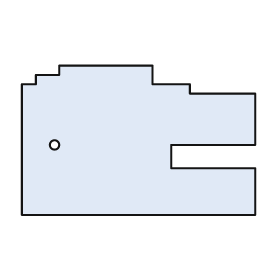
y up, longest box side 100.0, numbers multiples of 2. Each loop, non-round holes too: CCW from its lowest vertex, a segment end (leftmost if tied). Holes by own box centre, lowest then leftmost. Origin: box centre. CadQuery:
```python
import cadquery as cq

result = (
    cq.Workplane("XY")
    .moveTo(-50.0, -32.0)
    .lineTo(50.0, -32.0)
    .lineTo(50.0, -12.0)
    .lineTo(14.0, -12.0)
    .lineTo(14.0, -2.0)
    .lineTo(50.0, -2.0)
    .lineTo(50.0, 20.0)
    .lineTo(22.0, 20.0)
    .lineTo(22.0, 24.0)
    .lineTo(6.0, 24.0)
    .lineTo(6.0, 32.0)
    .lineTo(-34.0, 32.0)
    .lineTo(-34.0, 28.0)
    .lineTo(-44.0, 28.0)
    .lineTo(-44.0, 24.0)
    .lineTo(-50.0, 24.0)
    .close()
    .moveTo(-36.0, -2.0)
    .circle(2.0)
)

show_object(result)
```